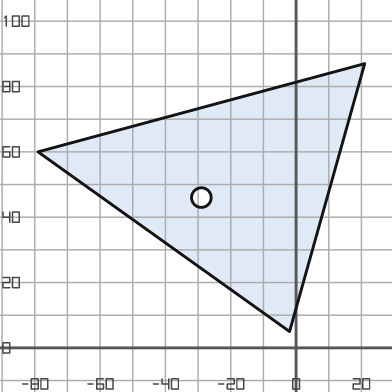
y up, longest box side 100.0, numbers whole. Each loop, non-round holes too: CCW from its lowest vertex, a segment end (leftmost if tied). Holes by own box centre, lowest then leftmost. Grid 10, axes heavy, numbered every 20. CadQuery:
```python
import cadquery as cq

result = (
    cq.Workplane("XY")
    .moveTo(-2.0, 5.0)
    .lineTo(21.0, 87.0)
    .lineTo(-79.0, 60.0)
    .close()
    .moveTo(-29.0, 46.0)
    .circle(3.0)
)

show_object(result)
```